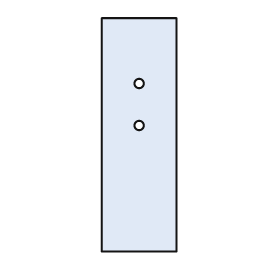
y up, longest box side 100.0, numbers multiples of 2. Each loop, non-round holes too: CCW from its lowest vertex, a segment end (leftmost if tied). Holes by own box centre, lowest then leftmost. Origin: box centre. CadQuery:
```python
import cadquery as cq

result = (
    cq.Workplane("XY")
    .moveTo(-16.0, -50.0)
    .lineTo(16.0, -50.0)
    .lineTo(16.0, 50.0)
    .lineTo(-16.0, 50.0)
    .close()
    .moveTo(0.0, 4.0)
    .circle(2.0)
    .moveTo(0.0, 22.0)
    .circle(2.0)
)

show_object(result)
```